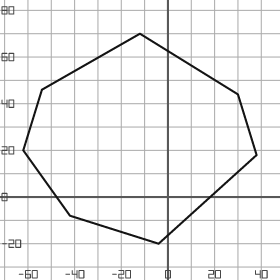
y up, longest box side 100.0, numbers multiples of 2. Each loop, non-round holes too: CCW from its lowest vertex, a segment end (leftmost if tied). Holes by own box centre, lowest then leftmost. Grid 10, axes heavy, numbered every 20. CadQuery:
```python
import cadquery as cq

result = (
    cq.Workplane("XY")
    .moveTo(-4.0, -20.0)
    .lineTo(38.0, 18.0)
    .lineTo(30.0, 44.0)
    .lineTo(-12.0, 70.0)
    .lineTo(-54.0, 46.0)
    .lineTo(-62.0, 20.0)
    .lineTo(-42.0, -8.0)
    .close()
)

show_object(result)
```